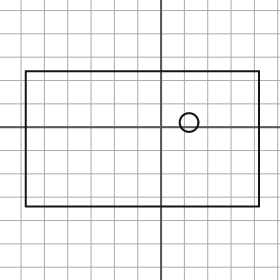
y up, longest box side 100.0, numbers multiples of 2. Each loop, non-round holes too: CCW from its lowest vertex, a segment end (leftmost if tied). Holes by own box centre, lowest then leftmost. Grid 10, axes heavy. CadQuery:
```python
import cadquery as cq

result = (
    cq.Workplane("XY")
    .moveTo(-58.0, -34.0)
    .lineTo(42.0, -34.0)
    .lineTo(42.0, 24.0)
    .lineTo(-58.0, 24.0)
    .close()
    .moveTo(12.0, 2.0)
    .circle(4.0)
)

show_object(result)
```